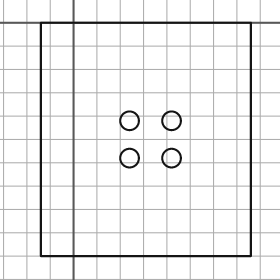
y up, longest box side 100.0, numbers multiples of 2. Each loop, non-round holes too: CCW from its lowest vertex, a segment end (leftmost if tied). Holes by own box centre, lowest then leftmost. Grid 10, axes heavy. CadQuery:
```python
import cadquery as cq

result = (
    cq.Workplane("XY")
    .moveTo(-14.0, -100.0)
    .lineTo(76.0, -100.0)
    .lineTo(76.0, 0.0)
    .lineTo(-14.0, 0.0)
    .close()
    .moveTo(24.0, -58.0)
    .circle(4.0)
    .moveTo(42.0, -58.0)
    .circle(4.0)
    .moveTo(24.0, -42.0)
    .circle(4.0)
    .moveTo(42.0, -42.0)
    .circle(4.0)
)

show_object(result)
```